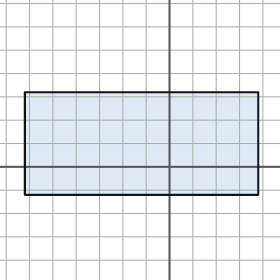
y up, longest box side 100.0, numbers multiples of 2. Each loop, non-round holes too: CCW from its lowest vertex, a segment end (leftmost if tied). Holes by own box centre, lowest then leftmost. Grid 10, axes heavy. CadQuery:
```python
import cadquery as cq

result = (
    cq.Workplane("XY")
    .moveTo(-62.0, -12.0)
    .lineTo(38.0, -12.0)
    .lineTo(38.0, 32.0)
    .lineTo(-62.0, 32.0)
    .close()
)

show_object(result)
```